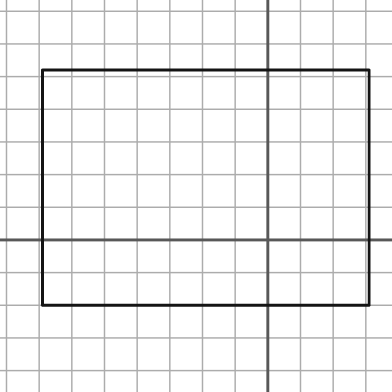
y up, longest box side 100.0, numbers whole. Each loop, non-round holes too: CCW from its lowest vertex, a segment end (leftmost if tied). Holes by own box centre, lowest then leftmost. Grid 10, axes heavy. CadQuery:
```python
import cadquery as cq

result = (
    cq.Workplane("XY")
    .moveTo(-69.0, -20.0)
    .lineTo(31.0, -20.0)
    .lineTo(31.0, 52.0)
    .lineTo(-69.0, 52.0)
    .close()
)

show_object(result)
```